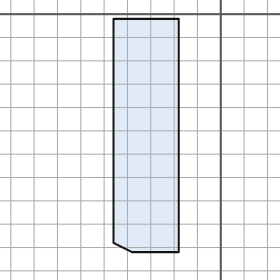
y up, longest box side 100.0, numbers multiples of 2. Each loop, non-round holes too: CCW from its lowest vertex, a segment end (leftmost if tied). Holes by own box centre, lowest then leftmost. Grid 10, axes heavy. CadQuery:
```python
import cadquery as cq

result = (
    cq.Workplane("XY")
    .moveTo(-38.0, -102.0)
    .lineTo(-18.0, -102.0)
    .lineTo(-18.0, -2.0)
    .lineTo(-46.0, -2.0)
    .lineTo(-46.0, -98.0)
    .close()
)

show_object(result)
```